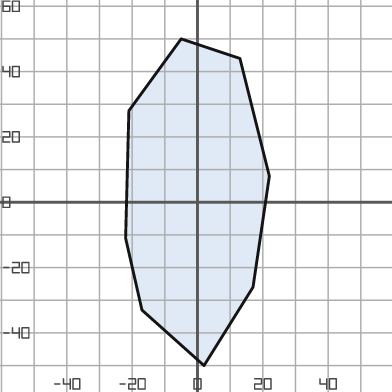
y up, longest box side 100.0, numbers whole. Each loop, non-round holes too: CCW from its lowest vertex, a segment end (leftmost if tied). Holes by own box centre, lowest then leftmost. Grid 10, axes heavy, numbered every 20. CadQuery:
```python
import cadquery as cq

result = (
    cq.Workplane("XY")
    .moveTo(2.0, -50.0)
    .lineTo(17.0, -26.0)
    .lineTo(22.0, 8.0)
    .lineTo(13.0, 44.0)
    .lineTo(-5.0, 50.0)
    .lineTo(-21.0, 28.0)
    .lineTo(-22.0, -11.0)
    .lineTo(-17.0, -33.0)
    .close()
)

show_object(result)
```